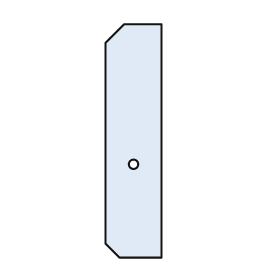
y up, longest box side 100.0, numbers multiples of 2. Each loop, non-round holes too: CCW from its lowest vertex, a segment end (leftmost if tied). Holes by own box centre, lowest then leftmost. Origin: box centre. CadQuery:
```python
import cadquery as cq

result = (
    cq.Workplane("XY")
    .moveTo(-6.0, -50.0)
    .lineTo(12.0, -50.0)
    .lineTo(12.0, 50.0)
    .lineTo(-4.0, 50.0)
    .lineTo(-12.0, 42.0)
    .lineTo(-12.0, -44.0)
    .close()
    .moveTo(0.0, -10.0)
    .circle(2.0)
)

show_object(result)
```